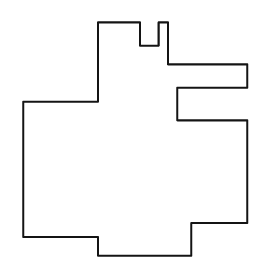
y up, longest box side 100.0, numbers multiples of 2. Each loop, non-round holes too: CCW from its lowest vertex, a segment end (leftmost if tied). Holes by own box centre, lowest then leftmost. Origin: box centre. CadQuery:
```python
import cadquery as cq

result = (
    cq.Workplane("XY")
    .moveTo(-16.0, -50.0)
    .lineTo(24.0, -50.0)
    .lineTo(24.0, -36.0)
    .lineTo(48.0, -36.0)
    .lineTo(48.0, 8.0)
    .lineTo(18.0, 8.0)
    .lineTo(18.0, 22.0)
    .lineTo(48.0, 22.0)
    .lineTo(48.0, 32.0)
    .lineTo(14.0, 32.0)
    .lineTo(14.0, 50.0)
    .lineTo(10.0, 50.0)
    .lineTo(10.0, 40.0)
    .lineTo(2.0, 40.0)
    .lineTo(2.0, 50.0)
    .lineTo(-16.0, 50.0)
    .lineTo(-16.0, 16.0)
    .lineTo(-48.0, 16.0)
    .lineTo(-48.0, -42.0)
    .lineTo(-16.0, -42.0)
    .close()
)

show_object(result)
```